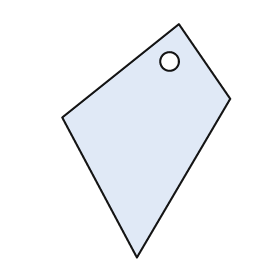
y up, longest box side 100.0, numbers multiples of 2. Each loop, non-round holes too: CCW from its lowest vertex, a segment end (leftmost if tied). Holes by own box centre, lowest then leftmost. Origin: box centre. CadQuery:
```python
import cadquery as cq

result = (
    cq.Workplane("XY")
    .moveTo(-4.0, -50.0)
    .lineTo(36.0, 18.0)
    .lineTo(14.0, 50.0)
    .lineTo(-36.0, 10.0)
    .close()
    .moveTo(10.0, 34.0)
    .circle(4.0)
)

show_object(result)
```